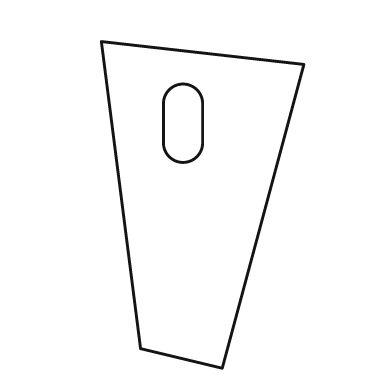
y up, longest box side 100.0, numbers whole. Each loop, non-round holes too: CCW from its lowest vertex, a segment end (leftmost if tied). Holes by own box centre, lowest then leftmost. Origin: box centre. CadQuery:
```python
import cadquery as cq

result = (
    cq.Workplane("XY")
    .moveTo(6.0, -50.0)
    .lineTo(31.0, 43.0)
    .lineTo(-31.0, 50.0)
    .lineTo(-19.0, -44.0)
    .close()
    .moveTo(-12.0, 19.0)
    .threePointArc((-6.0, 13.0), (0.0, 19.0))
    .lineTo(0.0, 31.0)
    .threePointArc((-6.0, 37.0), (-12.0, 31.0))
    .close()
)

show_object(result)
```